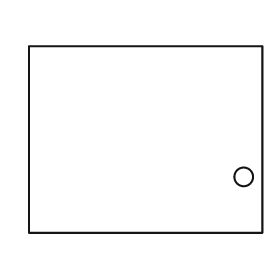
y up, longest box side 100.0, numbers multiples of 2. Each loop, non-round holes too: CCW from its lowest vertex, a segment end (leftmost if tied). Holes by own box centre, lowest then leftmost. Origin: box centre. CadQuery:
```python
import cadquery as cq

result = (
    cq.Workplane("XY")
    .moveTo(-50.0, -40.0)
    .lineTo(50.0, -40.0)
    .lineTo(50.0, 40.0)
    .lineTo(-50.0, 40.0)
    .close()
    .moveTo(42.0, -16.0)
    .circle(4.0)
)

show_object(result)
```